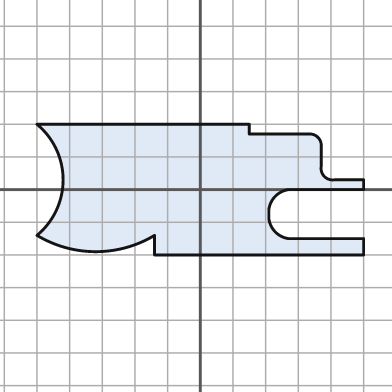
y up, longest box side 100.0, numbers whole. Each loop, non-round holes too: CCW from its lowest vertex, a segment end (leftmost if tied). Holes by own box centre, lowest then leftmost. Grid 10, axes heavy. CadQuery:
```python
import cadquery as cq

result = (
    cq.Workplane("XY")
    .moveTo(-14.0, -20.0)
    .lineTo(50.0, -20.0)
    .lineTo(50.0, -15.0)
    .lineTo(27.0, -15.0)
    .threePointArc((23.0, -13.0), (21.0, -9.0))
    .lineTo(21.0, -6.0)
    .threePointArc((23.0, -2.0), (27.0, 0.0))
    .lineTo(50.0, 0.0)
    .lineTo(50.0, 3.0)
    .lineTo(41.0, 3.0)
    .threePointArc((38.0, 4.0), (37.0, 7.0))
    .lineTo(37.0, 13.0)
    .threePointArc((36.0, 16.0), (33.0, 17.0))
    .lineTo(15.0, 17.0)
    .lineTo(15.0, 20.0)
    .lineTo(-50.0, 20.0)
    .threePointArc((-42.0, 3.0), (-50.0, -14.0))
    .threePointArc((-32.0, -19.0), (-14.0, -14.0))
    .close()
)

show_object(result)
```